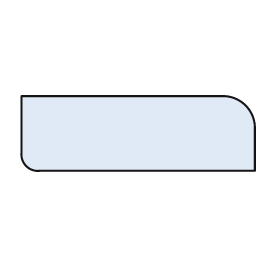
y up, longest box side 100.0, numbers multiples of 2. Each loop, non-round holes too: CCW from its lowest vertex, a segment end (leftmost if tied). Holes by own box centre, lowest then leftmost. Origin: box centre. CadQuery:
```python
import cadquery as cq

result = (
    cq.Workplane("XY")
    .moveTo(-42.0, -16.0)
    .lineTo(50.0, -16.0)
    .lineTo(50.0, 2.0)
    .threePointArc((46.0, 12.0), (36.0, 16.0))
    .lineTo(-50.0, 16.0)
    .lineTo(-50.0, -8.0)
    .threePointArc((-48.0, -14.0), (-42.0, -16.0))
    .close()
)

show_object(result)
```